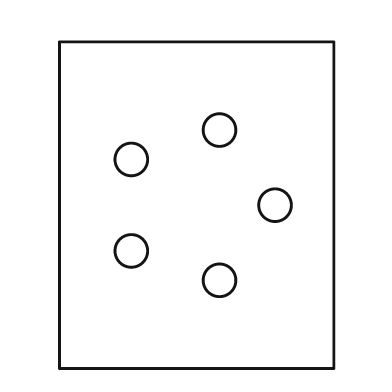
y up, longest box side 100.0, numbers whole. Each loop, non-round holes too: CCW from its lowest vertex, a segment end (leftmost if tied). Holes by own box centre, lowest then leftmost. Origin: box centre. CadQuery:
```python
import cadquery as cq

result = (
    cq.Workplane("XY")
    .moveTo(-42.0, -50.0)
    .lineTo(42.0, -50.0)
    .lineTo(42.0, 50.0)
    .lineTo(-42.0, 50.0)
    .close()
    .moveTo(7.0, -23.0)
    .circle(5.0)
    .moveTo(-20.0, -14.0)
    .circle(5.0)
    .moveTo(24.0, 0.0)
    .circle(5.0)
    .moveTo(-20.0, 14.0)
    .circle(5.0)
    .moveTo(7.0, 23.0)
    .circle(5.0)
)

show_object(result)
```